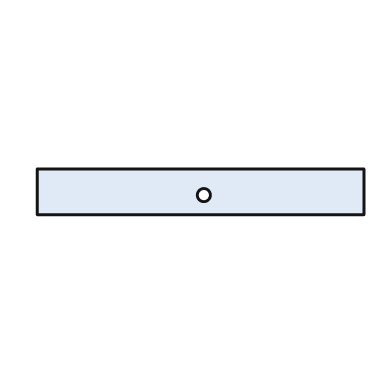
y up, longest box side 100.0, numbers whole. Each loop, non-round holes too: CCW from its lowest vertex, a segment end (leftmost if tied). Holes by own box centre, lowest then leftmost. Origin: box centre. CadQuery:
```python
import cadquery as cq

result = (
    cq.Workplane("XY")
    .moveTo(-50.0, -7.0)
    .lineTo(50.0, -7.0)
    .lineTo(50.0, 7.0)
    .lineTo(-50.0, 7.0)
    .close()
    .moveTo(1.0, -1.0)
    .circle(2.0)
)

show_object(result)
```